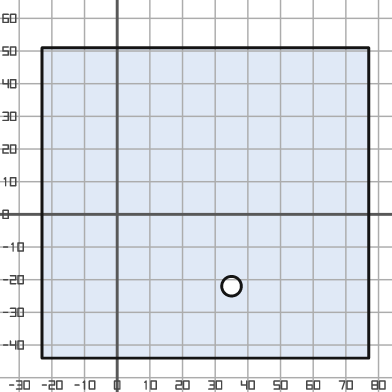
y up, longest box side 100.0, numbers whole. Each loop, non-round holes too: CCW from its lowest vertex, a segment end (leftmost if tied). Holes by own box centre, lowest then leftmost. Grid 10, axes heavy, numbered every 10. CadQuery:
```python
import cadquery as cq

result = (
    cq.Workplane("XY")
    .moveTo(-23.0, -44.0)
    .lineTo(77.0, -44.0)
    .lineTo(77.0, 51.0)
    .lineTo(-23.0, 51.0)
    .close()
    .moveTo(35.0, -22.0)
    .circle(3.0)
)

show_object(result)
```